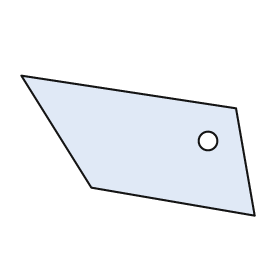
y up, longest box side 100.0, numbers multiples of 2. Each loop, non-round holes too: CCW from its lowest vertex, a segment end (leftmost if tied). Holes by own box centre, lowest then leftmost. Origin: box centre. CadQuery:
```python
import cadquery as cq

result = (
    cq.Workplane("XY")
    .moveTo(50.0, -30.0)
    .lineTo(42.0, 16.0)
    .lineTo(-50.0, 30.0)
    .lineTo(-20.0, -18.0)
    .close()
    .moveTo(30.0, 2.0)
    .circle(4.0)
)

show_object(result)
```